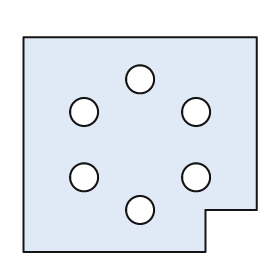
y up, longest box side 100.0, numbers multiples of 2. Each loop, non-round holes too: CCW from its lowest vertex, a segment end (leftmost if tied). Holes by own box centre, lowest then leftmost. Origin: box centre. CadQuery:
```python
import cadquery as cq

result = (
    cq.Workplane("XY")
    .moveTo(-50.0, -46.0)
    .lineTo(28.0, -46.0)
    .lineTo(28.0, -28.0)
    .lineTo(50.0, -28.0)
    .lineTo(50.0, 46.0)
    .lineTo(-50.0, 46.0)
    .close()
    .moveTo(0.0, -28.0)
    .circle(6.0)
    .moveTo(-24.0, -14.0)
    .circle(6.0)
    .moveTo(24.0, -14.0)
    .circle(6.0)
    .moveTo(-24.0, 14.0)
    .circle(6.0)
    .moveTo(24.0, 14.0)
    .circle(6.0)
    .moveTo(0.0, 28.0)
    .circle(6.0)
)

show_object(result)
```